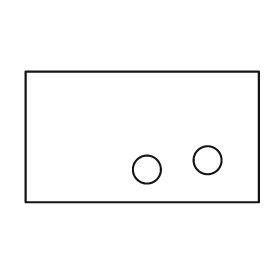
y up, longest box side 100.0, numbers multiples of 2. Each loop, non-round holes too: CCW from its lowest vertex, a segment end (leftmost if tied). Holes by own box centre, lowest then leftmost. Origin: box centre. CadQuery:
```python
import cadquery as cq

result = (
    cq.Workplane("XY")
    .moveTo(-50.0, -28.0)
    .lineTo(50.0, -28.0)
    .lineTo(50.0, 28.0)
    .lineTo(-50.0, 28.0)
    .close()
    .moveTo(2.0, -14.0)
    .circle(6.0)
    .moveTo(28.0, -10.0)
    .circle(6.0)
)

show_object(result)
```